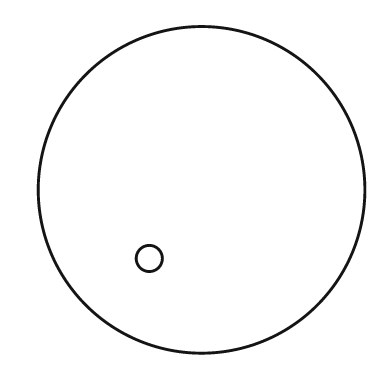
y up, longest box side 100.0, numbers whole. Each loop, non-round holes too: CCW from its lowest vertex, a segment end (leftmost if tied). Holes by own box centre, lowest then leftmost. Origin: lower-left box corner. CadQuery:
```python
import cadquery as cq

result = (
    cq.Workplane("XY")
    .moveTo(50.0, 50.0)
    .circle(50.0)
    .moveTo(34.0, 29.0)
    .circle(4.0)
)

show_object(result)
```